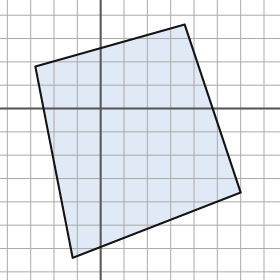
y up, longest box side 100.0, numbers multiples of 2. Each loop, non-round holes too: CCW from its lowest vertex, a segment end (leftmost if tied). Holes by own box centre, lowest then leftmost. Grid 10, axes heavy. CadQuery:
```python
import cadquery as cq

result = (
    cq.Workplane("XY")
    .moveTo(-12.0, -64.0)
    .lineTo(60.0, -36.0)
    .lineTo(36.0, 36.0)
    .lineTo(-28.0, 18.0)
    .close()
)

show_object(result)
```